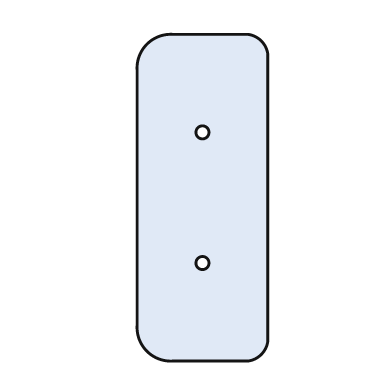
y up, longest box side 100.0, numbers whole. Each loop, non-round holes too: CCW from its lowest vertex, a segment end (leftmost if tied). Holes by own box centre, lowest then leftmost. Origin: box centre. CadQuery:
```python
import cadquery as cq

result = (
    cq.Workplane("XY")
    .moveTo(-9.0, -50.0)
    .lineTo(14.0, -50.0)
    .threePointArc((18.0, -48.0), (20.0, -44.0))
    .lineTo(20.0, 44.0)
    .threePointArc((18.0, 48.0), (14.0, 50.0))
    .lineTo(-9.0, 50.0)
    .threePointArc((-17.0, 47.0), (-20.0, 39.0))
    .lineTo(-20.0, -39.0)
    .threePointArc((-17.0, -47.0), (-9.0, -50.0))
    .close()
    .moveTo(0.0, -20.0)
    .circle(2.0)
    .moveTo(0.0, 20.0)
    .circle(2.0)
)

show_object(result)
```